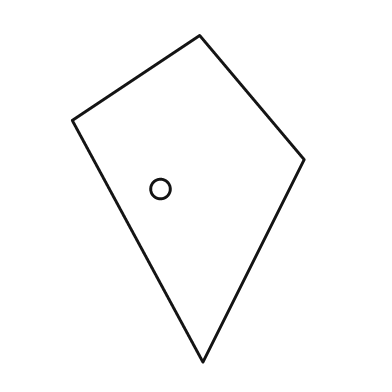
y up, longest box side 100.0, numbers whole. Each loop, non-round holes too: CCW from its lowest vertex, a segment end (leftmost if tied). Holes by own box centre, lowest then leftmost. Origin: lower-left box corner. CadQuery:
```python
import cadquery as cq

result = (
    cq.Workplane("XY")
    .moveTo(40.0, 0.0)
    .lineTo(71.0, 62.0)
    .lineTo(39.0, 100.0)
    .lineTo(0.0, 74.0)
    .close()
    .moveTo(27.0, 53.0)
    .circle(3.0)
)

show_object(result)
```